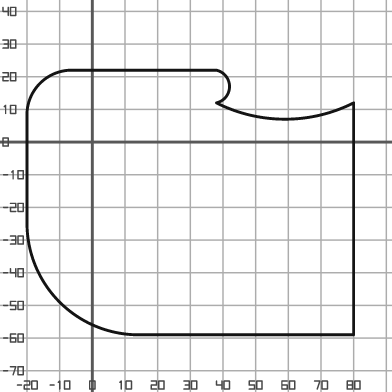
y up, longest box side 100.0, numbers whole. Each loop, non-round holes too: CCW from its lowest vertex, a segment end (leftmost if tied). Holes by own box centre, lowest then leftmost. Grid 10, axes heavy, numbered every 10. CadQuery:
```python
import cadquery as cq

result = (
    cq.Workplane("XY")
    .moveTo(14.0, -59.0)
    .lineTo(80.0, -59.0)
    .lineTo(80.0, 12.0)
    .threePointArc((59.0, 7.0), (38.0, 12.0))
    .threePointArc((42.0, 17.0), (38.0, 22.0))
    .lineTo(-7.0, 22.0)
    .threePointArc((-16.0, 18.0), (-20.0, 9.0))
    .lineTo(-20.0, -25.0)
    .threePointArc((-10.0, -49.0), (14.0, -59.0))
    .close()
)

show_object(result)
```